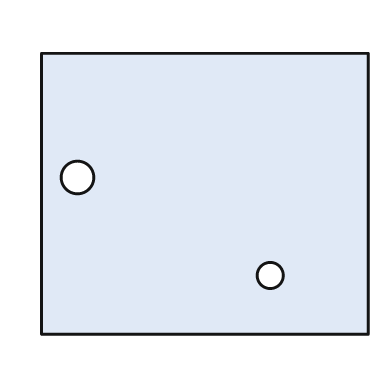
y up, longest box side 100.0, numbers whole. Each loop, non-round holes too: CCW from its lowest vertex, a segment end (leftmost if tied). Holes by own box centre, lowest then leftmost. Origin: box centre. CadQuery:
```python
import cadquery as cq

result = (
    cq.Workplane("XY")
    .moveTo(-50.0, -43.0)
    .lineTo(50.0, -43.0)
    .lineTo(50.0, 43.0)
    .lineTo(-50.0, 43.0)
    .close()
    .moveTo(20.0, -25.0)
    .circle(4.0)
    .moveTo(-39.0, 5.0)
    .circle(5.0)
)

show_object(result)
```